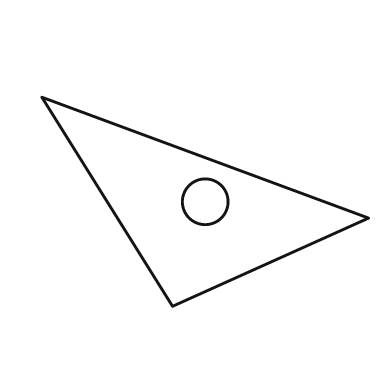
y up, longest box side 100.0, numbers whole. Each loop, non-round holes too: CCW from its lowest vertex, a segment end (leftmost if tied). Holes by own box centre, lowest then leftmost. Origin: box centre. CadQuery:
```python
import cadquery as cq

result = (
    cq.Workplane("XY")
    .moveTo(-10.0, -32.0)
    .lineTo(50.0, -5.0)
    .lineTo(-50.0, 32.0)
    .close()
    .moveTo(0.0, 0.0)
    .circle(7.0)
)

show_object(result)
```